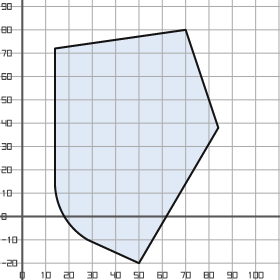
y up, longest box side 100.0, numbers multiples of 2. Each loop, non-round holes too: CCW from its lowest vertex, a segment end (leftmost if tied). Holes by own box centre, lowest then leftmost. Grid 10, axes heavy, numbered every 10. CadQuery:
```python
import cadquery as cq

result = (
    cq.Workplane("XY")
    .moveTo(50.0, -20.0)
    .lineTo(84.0, 38.0)
    .lineTo(70.0, 80.0)
    .lineTo(14.0, 72.0)
    .lineTo(14.0, 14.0)
    .threePointArc((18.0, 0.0), (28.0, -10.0))
    .close()
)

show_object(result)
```